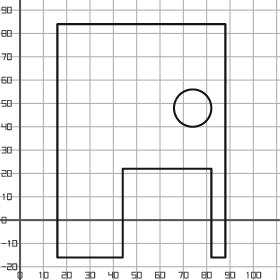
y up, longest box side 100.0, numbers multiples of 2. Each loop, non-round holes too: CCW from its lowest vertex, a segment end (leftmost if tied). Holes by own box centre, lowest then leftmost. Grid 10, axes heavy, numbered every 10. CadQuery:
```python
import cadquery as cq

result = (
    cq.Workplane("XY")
    .moveTo(16.0, -16.0)
    .lineTo(44.0, -16.0)
    .lineTo(44.0, 22.0)
    .lineTo(82.0, 22.0)
    .lineTo(82.0, -16.0)
    .lineTo(88.0, -16.0)
    .lineTo(88.0, 84.0)
    .lineTo(16.0, 84.0)
    .close()
    .moveTo(74.0, 48.0)
    .circle(8.0)
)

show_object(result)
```